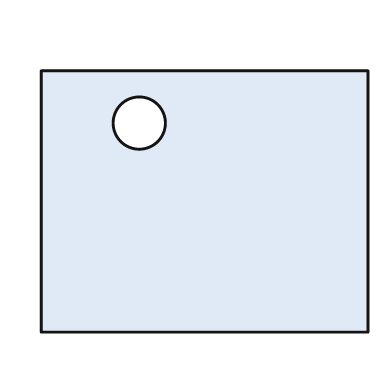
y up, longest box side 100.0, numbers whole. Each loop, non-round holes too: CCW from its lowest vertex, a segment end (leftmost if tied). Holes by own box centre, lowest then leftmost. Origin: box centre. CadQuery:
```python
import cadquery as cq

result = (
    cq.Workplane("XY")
    .moveTo(-50.0, -40.0)
    .lineTo(50.0, -40.0)
    .lineTo(50.0, 40.0)
    .lineTo(-50.0, 40.0)
    .close()
    .moveTo(-20.0, 24.0)
    .circle(8.0)
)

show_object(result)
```